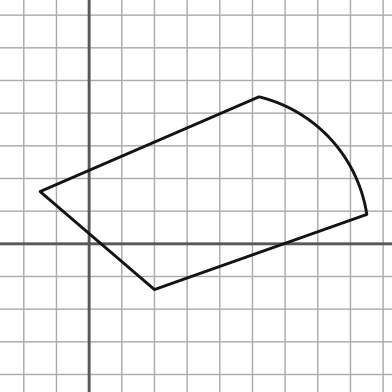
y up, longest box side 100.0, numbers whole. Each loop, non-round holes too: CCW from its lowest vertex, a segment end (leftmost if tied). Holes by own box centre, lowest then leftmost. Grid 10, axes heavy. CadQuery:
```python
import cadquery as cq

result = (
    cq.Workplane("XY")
    .moveTo(20.0, -14.0)
    .lineTo(85.0, 9.0)
    .threePointArc((74.0, 32.0), (52.0, 45.0))
    .lineTo(-15.0, 16.0)
    .close()
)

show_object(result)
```